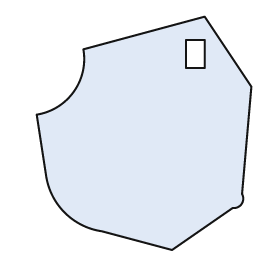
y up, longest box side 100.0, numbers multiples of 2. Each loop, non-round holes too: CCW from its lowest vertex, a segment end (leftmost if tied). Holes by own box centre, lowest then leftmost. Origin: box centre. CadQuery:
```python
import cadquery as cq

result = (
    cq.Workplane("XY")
    .moveTo(12.0, -50.0)
    .lineTo(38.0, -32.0)
    .threePointArc((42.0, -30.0), (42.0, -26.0))
    .lineTo(46.0, 20.0)
    .lineTo(26.0, 50.0)
    .lineTo(-26.0, 36.0)
    .threePointArc((-30.0, 18.0), (-46.0, 8.0))
    .lineTo(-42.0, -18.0)
    .threePointArc((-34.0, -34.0), (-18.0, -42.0))
    .close()
    .moveTo(18.0, 28.0)
    .lineTo(26.0, 28.0)
    .lineTo(26.0, 40.0)
    .lineTo(18.0, 40.0)
    .close()
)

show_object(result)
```